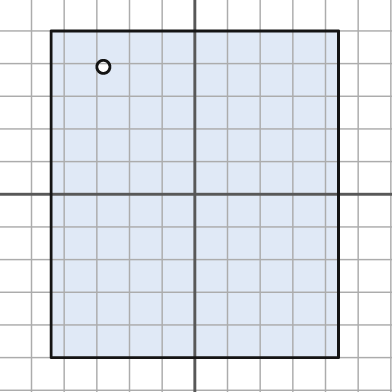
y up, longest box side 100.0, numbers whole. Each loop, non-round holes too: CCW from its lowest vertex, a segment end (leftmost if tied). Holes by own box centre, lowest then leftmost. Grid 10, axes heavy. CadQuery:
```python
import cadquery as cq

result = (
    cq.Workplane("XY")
    .moveTo(-44.0, -50.0)
    .lineTo(44.0, -50.0)
    .lineTo(44.0, 50.0)
    .lineTo(-44.0, 50.0)
    .close()
    .moveTo(-28.0, 39.0)
    .circle(2.0)
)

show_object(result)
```